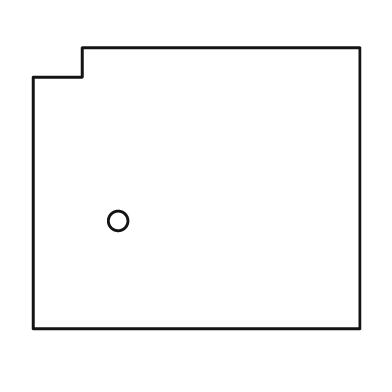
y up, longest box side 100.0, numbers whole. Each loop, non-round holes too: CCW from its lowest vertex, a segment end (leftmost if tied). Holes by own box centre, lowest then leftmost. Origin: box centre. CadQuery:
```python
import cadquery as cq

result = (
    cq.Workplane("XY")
    .moveTo(-50.0, -43.0)
    .lineTo(50.0, -43.0)
    .lineTo(50.0, 43.0)
    .lineTo(-35.0, 43.0)
    .lineTo(-35.0, 34.0)
    .lineTo(-50.0, 34.0)
    .close()
    .moveTo(-24.0, -10.0)
    .circle(3.0)
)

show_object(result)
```